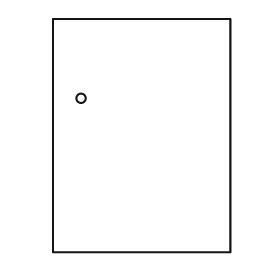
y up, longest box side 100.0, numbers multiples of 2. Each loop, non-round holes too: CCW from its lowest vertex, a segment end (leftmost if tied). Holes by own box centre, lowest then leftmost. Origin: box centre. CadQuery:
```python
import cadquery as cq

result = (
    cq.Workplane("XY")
    .moveTo(-38.0, -50.0)
    .lineTo(38.0, -50.0)
    .lineTo(38.0, 50.0)
    .lineTo(-38.0, 50.0)
    .close()
    .moveTo(-26.0, 16.0)
    .circle(2.0)
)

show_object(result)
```